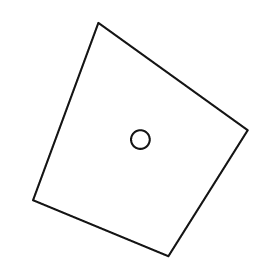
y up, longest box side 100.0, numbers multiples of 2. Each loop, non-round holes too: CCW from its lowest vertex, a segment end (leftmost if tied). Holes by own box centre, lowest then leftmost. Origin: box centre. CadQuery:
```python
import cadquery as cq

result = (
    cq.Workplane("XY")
    .moveTo(12.0, -50.0)
    .lineTo(46.0, 4.0)
    .lineTo(-18.0, 50.0)
    .lineTo(-46.0, -26.0)
    .close()
    .moveTo(0.0, 0.0)
    .circle(4.0)
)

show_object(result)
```